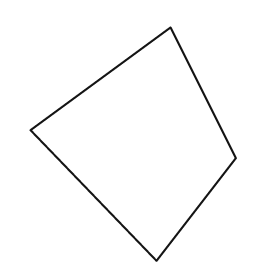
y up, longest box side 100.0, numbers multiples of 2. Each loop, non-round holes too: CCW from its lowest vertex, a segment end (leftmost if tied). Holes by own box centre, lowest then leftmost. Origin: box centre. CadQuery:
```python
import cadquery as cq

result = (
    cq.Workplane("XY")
    .moveTo(10.0, -50.0)
    .lineTo(44.0, -6.0)
    .lineTo(16.0, 50.0)
    .lineTo(-44.0, 6.0)
    .close()
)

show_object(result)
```